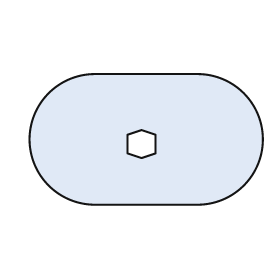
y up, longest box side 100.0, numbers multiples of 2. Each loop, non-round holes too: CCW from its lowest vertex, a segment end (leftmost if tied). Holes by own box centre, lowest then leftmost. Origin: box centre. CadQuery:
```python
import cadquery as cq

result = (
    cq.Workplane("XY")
    .moveTo(-22.0, -28.0)
    .lineTo(22.0, -28.0)
    .threePointArc((50.0, 0.0), (22.0, 28.0))
    .lineTo(-22.0, 28.0)
    .threePointArc((-50.0, 0.0), (-22.0, -28.0))
    .close()
    .moveTo(-2.0, -8.0)
    .lineTo(4.0, -6.0)
    .lineTo(4.0, 2.0)
    .lineTo(-2.0, 4.0)
    .lineTo(-8.0, 2.0)
    .lineTo(-8.0, -6.0)
    .close()
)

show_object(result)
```